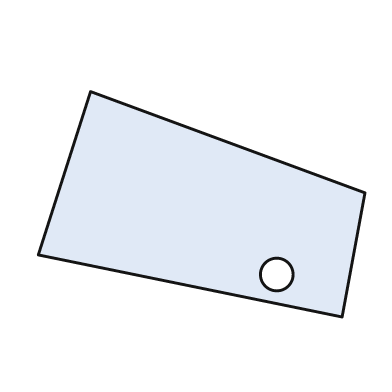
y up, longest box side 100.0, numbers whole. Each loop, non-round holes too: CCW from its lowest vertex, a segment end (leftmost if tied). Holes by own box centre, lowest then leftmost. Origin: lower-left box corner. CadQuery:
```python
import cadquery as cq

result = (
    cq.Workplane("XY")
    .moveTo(93.0, 0.0)
    .lineTo(100.0, 38.0)
    .lineTo(16.0, 69.0)
    .lineTo(0.0, 19.0)
    .close()
    .moveTo(73.0, 13.0)
    .circle(5.0)
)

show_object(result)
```